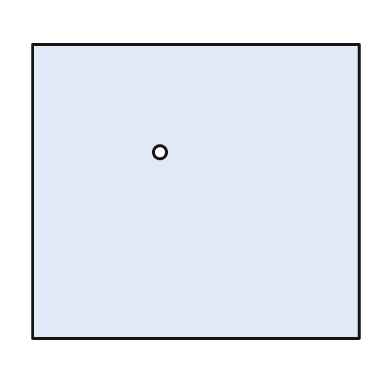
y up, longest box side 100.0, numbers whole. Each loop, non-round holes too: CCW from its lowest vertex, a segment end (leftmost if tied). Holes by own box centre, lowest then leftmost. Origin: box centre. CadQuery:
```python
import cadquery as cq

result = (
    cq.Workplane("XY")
    .moveTo(-50.0, -45.0)
    .lineTo(50.0, -45.0)
    .lineTo(50.0, 45.0)
    .lineTo(-50.0, 45.0)
    .close()
    .moveTo(-11.0, 12.0)
    .circle(2.0)
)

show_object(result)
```